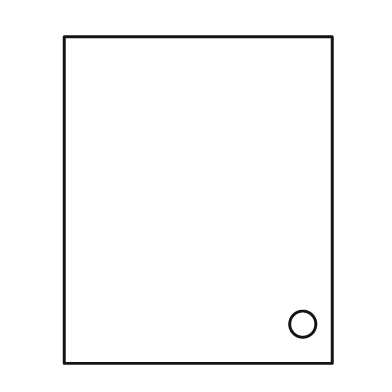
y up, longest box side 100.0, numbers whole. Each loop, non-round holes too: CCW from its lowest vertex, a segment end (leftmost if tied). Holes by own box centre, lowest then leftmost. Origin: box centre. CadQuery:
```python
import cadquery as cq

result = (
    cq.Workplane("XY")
    .moveTo(-41.0, -50.0)
    .lineTo(41.0, -50.0)
    .lineTo(41.0, 50.0)
    .lineTo(-41.0, 50.0)
    .close()
    .moveTo(32.0, -38.0)
    .circle(4.0)
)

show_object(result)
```